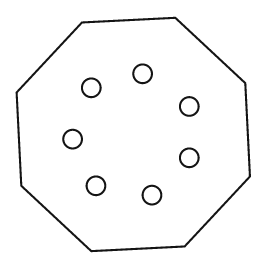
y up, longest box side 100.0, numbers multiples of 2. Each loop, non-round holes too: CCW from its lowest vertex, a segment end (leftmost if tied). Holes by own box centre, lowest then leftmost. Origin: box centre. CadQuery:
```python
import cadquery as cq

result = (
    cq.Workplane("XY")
    .moveTo(-18.0, -50.0)
    .lineTo(22.0, -48.0)
    .lineTo(50.0, -18.0)
    .lineTo(48.0, 22.0)
    .lineTo(18.0, 50.0)
    .lineTo(-22.0, 48.0)
    .lineTo(-50.0, 18.0)
    .lineTo(-48.0, -22.0)
    .close()
    .moveTo(8.0, -26.0)
    .circle(4.0)
    .moveTo(-16.0, -22.0)
    .circle(4.0)
    .moveTo(24.0, -10.0)
    .circle(4.0)
    .moveTo(-26.0, -2.0)
    .circle(4.0)
    .moveTo(24.0, 12.0)
    .circle(4.0)
    .moveTo(-18.0, 20.0)
    .circle(4.0)
    .moveTo(4.0, 26.0)
    .circle(4.0)
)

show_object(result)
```